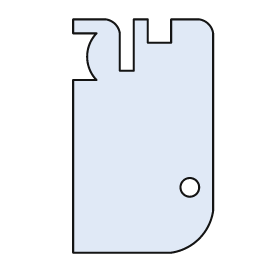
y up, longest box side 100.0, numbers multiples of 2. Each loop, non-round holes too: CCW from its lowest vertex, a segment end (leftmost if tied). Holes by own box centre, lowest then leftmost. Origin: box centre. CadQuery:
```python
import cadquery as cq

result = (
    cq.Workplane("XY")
    .moveTo(-30.0, -50.0)
    .lineTo(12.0, -50.0)
    .threePointArc((24.0, -44.0), (30.0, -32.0))
    .lineTo(30.0, 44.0)
    .threePointArc((28.0, 48.0), (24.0, 50.0))
    .lineTo(12.0, 50.0)
    .lineTo(12.0, 40.0)
    .lineTo(2.0, 40.0)
    .lineTo(2.0, 50.0)
    .lineTo(-4.0, 50.0)
    .lineTo(-4.0, 28.0)
    .lineTo(-10.0, 28.0)
    .lineTo(-10.0, 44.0)
    .threePointArc((-12.0, 48.0), (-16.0, 50.0))
    .lineTo(-30.0, 50.0)
    .lineTo(-30.0, 44.0)
    .lineTo(-20.0, 44.0)
    .threePointArc((-24.0, 34.0), (-20.0, 24.0))
    .lineTo(-30.0, 24.0)
    .close()
    .moveTo(20.0, -22.0)
    .circle(4.0)
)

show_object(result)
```